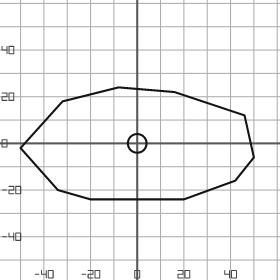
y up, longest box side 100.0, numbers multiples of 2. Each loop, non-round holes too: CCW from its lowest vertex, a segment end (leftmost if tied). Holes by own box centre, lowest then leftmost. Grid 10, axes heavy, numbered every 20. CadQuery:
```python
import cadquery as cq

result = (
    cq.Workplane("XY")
    .moveTo(-20.0, -24.0)
    .lineTo(20.0, -24.0)
    .lineTo(42.0, -16.0)
    .lineTo(50.0, -6.0)
    .lineTo(46.0, 12.0)
    .lineTo(16.0, 22.0)
    .lineTo(-8.0, 24.0)
    .lineTo(-32.0, 18.0)
    .lineTo(-50.0, -2.0)
    .lineTo(-34.0, -20.0)
    .close()
    .moveTo(0.0, 0.0)
    .circle(4.0)
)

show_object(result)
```